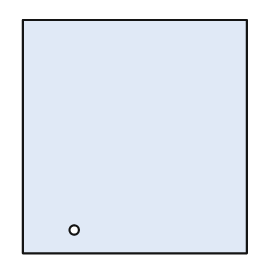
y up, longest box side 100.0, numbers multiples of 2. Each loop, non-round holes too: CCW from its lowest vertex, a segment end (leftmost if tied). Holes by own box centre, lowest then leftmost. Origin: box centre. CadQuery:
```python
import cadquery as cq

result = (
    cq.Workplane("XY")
    .moveTo(-48.0, -50.0)
    .lineTo(48.0, -50.0)
    .lineTo(48.0, 50.0)
    .lineTo(-48.0, 50.0)
    .close()
    .moveTo(-26.0, -40.0)
    .circle(2.0)
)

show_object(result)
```